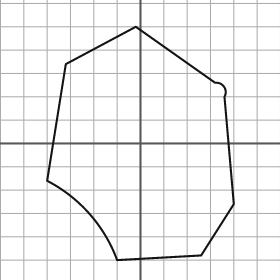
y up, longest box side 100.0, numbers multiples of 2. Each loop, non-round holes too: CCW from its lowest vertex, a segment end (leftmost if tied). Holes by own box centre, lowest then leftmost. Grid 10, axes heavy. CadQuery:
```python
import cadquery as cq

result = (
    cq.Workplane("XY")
    .moveTo(-10.0, -50.0)
    .lineTo(26.0, -48.0)
    .lineTo(40.0, -26.0)
    .lineTo(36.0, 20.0)
    .threePointArc((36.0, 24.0), (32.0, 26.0))
    .lineTo(-2.0, 50.0)
    .lineTo(-32.0, 34.0)
    .lineTo(-40.0, -16.0)
    .threePointArc((-22.0, -30.0), (-10.0, -50.0))
    .close()
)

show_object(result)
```